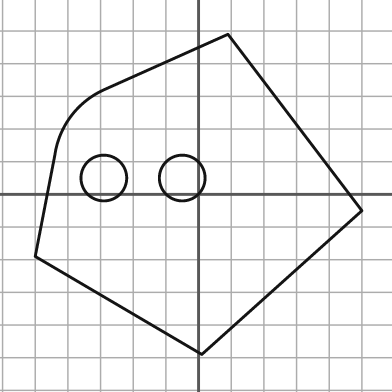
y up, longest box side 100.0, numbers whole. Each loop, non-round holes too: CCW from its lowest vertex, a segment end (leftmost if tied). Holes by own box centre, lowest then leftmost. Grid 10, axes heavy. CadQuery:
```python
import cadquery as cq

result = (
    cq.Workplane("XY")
    .moveTo(1.0, -49.0)
    .lineTo(50.0, -5.0)
    .lineTo(9.0, 49.0)
    .lineTo(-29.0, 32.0)
    .threePointArc((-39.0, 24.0), (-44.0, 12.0))
    .lineTo(-50.0, -19.0)
    .close()
    .moveTo(-29.0, 5.0)
    .circle(7.0)
    .moveTo(-5.0, 5.0)
    .circle(7.0)
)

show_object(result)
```